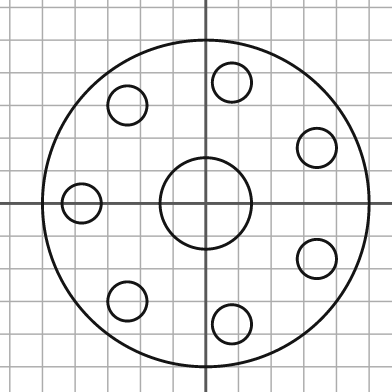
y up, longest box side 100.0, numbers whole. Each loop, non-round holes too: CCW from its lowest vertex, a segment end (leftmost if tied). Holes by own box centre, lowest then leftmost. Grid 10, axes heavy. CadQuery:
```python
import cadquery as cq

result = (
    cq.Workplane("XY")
    .moveTo(0.0, 0.0)
    .circle(50.0)
    .moveTo(8.0, -37.0)
    .circle(6.0)
    .moveTo(-24.0, -30.0)
    .circle(6.0)
    .moveTo(34.0, -17.0)
    .circle(6.0)
    .moveTo(-38.0, 0.0)
    .circle(6.0)
    .moveTo(0.0, 0.0)
    .circle(14.0)
    .moveTo(34.0, 17.0)
    .circle(6.0)
    .moveTo(-24.0, 30.0)
    .circle(6.0)
    .moveTo(8.0, 37.0)
    .circle(6.0)
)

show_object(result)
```